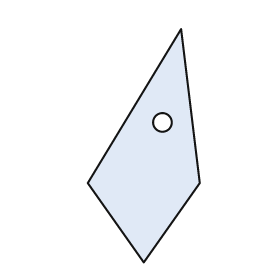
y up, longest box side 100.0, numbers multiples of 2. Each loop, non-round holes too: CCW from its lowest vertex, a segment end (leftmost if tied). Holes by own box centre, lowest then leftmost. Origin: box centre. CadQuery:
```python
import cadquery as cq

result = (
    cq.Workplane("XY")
    .moveTo(0.0, -50.0)
    .lineTo(24.0, -16.0)
    .lineTo(16.0, 50.0)
    .lineTo(-24.0, -16.0)
    .close()
    .moveTo(8.0, 10.0)
    .circle(4.0)
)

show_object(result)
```